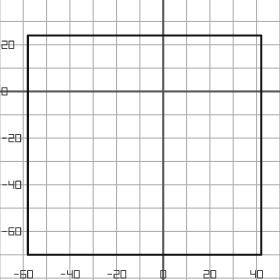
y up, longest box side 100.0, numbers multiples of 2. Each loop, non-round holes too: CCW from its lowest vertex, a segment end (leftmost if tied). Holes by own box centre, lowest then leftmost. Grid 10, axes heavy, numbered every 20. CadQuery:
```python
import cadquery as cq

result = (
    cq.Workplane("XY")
    .moveTo(-58.0, -70.0)
    .lineTo(42.0, -70.0)
    .lineTo(42.0, 24.0)
    .lineTo(-58.0, 24.0)
    .close()
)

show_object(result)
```